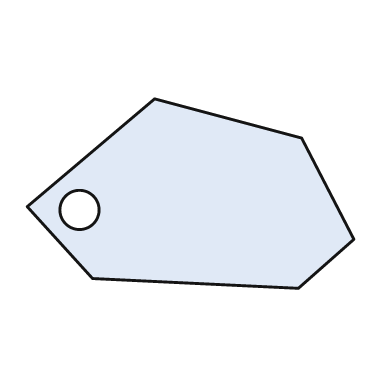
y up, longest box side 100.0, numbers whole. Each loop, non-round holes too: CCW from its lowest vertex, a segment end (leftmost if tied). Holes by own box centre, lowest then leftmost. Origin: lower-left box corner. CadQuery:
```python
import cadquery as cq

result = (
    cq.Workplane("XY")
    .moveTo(83.0, 0.0)
    .lineTo(100.0, 15.0)
    .lineTo(84.0, 46.0)
    .lineTo(39.0, 58.0)
    .lineTo(0.0, 25.0)
    .lineTo(20.0, 3.0)
    .close()
    .moveTo(16.0, 24.0)
    .circle(6.0)
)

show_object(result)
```